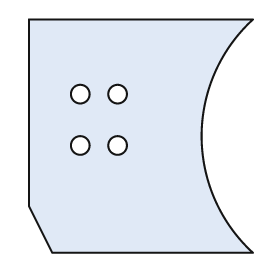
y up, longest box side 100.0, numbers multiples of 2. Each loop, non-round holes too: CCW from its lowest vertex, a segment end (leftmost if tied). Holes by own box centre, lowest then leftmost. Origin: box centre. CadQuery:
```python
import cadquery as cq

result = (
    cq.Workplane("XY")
    .moveTo(-38.0, -50.0)
    .lineTo(48.0, -50.0)
    .threePointArc((26.0, 0.0), (48.0, 50.0))
    .lineTo(-48.0, 50.0)
    .lineTo(-48.0, -30.0)
    .close()
    .moveTo(-26.0, -4.0)
    .circle(4.0)
    .moveTo(-10.0, -4.0)
    .circle(4.0)
    .moveTo(-26.0, 18.0)
    .circle(4.0)
    .moveTo(-10.0, 18.0)
    .circle(4.0)
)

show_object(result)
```